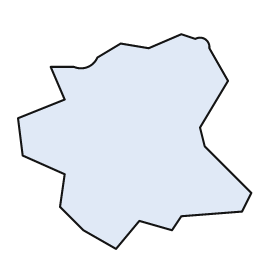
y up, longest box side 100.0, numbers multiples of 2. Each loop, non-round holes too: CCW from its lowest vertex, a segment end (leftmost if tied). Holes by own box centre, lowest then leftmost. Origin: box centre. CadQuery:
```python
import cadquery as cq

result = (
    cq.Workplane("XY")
    .moveTo(-8.0, -46.0)
    .lineTo(2.0, -34.0)
    .lineTo(16.0, -38.0)
    .lineTo(20.0, -32.0)
    .lineTo(46.0, -30.0)
    .lineTo(50.0, -22.0)
    .lineTo(30.0, -2.0)
    .lineTo(28.0, 6.0)
    .lineTo(40.0, 26.0)
    .lineTo(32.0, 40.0)
    .threePointArc((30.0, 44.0), (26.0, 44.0))
    .lineTo(20.0, 46.0)
    .lineTo(6.0, 40.0)
    .lineTo(-6.0, 42.0)
    .lineTo(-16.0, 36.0)
    .threePointArc((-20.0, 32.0), (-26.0, 32.0))
    .lineTo(-36.0, 32.0)
    .lineTo(-30.0, 18.0)
    .lineTo(-50.0, 10.0)
    .lineTo(-48.0, -6.0)
    .lineTo(-30.0, -14.0)
    .lineTo(-32.0, -28.0)
    .lineTo(-22.0, -38.0)
    .close()
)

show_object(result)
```